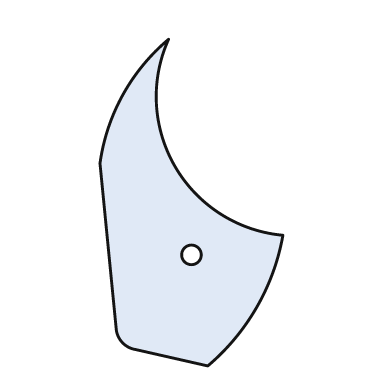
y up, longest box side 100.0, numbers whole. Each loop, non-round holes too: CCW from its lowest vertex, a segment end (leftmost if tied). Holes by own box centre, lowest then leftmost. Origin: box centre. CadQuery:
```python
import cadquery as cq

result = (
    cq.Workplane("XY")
    .moveTo(5.0, -50.0)
    .threePointArc((20.0, -32.0), (28.0, -10.0))
    .threePointArc((-5.0, 11.0), (-7.0, 50.0))
    .threePointArc((-21.0, 33.0), (-28.0, 12.0))
    .lineTo(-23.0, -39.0)
    .threePointArc((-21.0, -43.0), (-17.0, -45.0))
    .close()
    .moveTo(0.0, -16.0)
    .circle(3.0)
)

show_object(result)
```